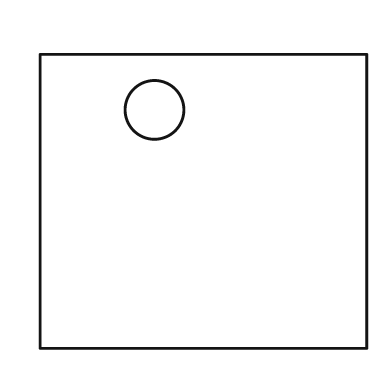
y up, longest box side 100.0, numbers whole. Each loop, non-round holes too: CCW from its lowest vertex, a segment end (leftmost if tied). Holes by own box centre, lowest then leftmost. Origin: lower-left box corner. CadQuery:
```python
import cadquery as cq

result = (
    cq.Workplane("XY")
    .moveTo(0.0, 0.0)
    .lineTo(100.0, 0.0)
    .lineTo(100.0, 90.0)
    .lineTo(0.0, 90.0)
    .close()
    .moveTo(35.0, 73.0)
    .circle(9.0)
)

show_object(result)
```